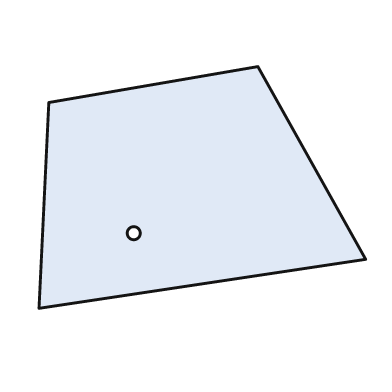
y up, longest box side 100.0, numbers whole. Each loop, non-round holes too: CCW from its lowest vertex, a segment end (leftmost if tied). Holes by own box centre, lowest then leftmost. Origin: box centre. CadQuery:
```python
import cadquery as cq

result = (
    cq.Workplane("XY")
    .moveTo(-50.0, -37.0)
    .lineTo(50.0, -22.0)
    .lineTo(17.0, 37.0)
    .lineTo(-47.0, 26.0)
    .close()
    .moveTo(-21.0, -14.0)
    .circle(2.0)
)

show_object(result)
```